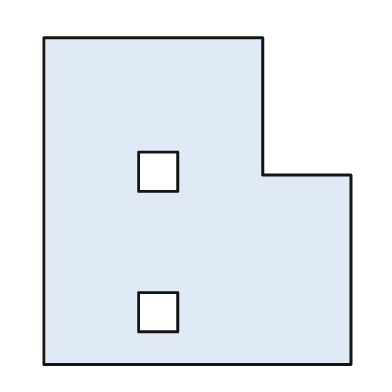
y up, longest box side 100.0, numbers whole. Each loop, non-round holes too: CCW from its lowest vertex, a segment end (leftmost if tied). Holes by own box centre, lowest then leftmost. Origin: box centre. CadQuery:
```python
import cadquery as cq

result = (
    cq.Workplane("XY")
    .moveTo(-47.0, -50.0)
    .lineTo(47.0, -50.0)
    .lineTo(47.0, 8.0)
    .lineTo(20.0, 8.0)
    .lineTo(20.0, 50.0)
    .lineTo(-47.0, 50.0)
    .close()
    .moveTo(-18.0, -40.0)
    .lineTo(-6.0, -40.0)
    .lineTo(-6.0, -28.0)
    .lineTo(-18.0, -28.0)
    .close()
    .moveTo(-18.0, 3.0)
    .lineTo(-6.0, 3.0)
    .lineTo(-6.0, 15.0)
    .lineTo(-18.0, 15.0)
    .close()
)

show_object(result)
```